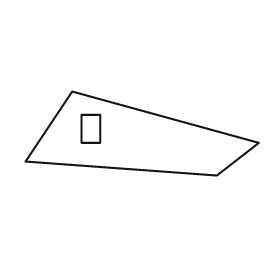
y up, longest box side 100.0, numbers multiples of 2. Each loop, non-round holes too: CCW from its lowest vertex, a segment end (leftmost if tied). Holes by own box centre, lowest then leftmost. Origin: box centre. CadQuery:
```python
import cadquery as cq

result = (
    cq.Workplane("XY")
    .moveTo(32.0, -18.0)
    .lineTo(50.0, -4.0)
    .lineTo(-30.0, 18.0)
    .lineTo(-50.0, -12.0)
    .close()
    .moveTo(-26.0, -4.0)
    .lineTo(-18.0, -4.0)
    .lineTo(-18.0, 8.0)
    .lineTo(-26.0, 8.0)
    .close()
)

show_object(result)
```